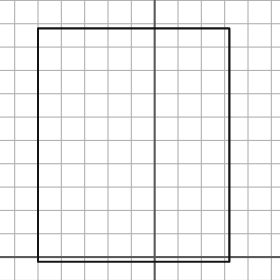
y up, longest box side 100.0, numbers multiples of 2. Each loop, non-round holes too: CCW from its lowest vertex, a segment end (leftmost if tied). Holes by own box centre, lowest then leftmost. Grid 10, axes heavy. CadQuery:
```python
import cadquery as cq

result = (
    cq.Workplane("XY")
    .moveTo(-50.0, -2.0)
    .lineTo(32.0, -2.0)
    .lineTo(32.0, 98.0)
    .lineTo(-50.0, 98.0)
    .close()
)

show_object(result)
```